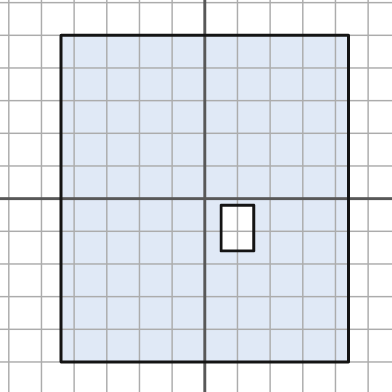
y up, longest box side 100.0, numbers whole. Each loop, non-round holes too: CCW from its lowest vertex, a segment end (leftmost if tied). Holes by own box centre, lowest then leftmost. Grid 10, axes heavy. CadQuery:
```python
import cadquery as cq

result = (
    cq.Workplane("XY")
    .moveTo(-44.0, -50.0)
    .lineTo(44.0, -50.0)
    .lineTo(44.0, 50.0)
    .lineTo(-44.0, 50.0)
    .close()
    .moveTo(5.0, -16.0)
    .lineTo(15.0, -16.0)
    .lineTo(15.0, -2.0)
    .lineTo(5.0, -2.0)
    .close()
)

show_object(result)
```